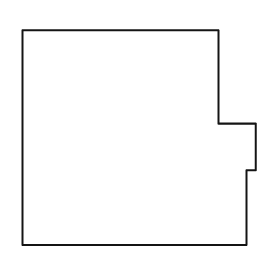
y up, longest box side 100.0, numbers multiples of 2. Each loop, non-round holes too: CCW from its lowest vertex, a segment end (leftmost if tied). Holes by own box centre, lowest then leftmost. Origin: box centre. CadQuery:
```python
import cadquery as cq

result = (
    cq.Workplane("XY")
    .moveTo(-50.0, -46.0)
    .lineTo(46.0, -46.0)
    .lineTo(46.0, -14.0)
    .lineTo(50.0, -14.0)
    .lineTo(50.0, 6.0)
    .lineTo(34.0, 6.0)
    .lineTo(34.0, 46.0)
    .lineTo(-50.0, 46.0)
    .close()
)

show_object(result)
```